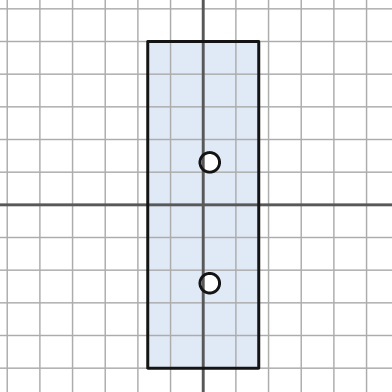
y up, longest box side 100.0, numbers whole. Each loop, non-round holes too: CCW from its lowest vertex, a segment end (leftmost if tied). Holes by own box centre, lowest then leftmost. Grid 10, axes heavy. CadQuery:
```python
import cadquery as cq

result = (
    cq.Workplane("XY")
    .moveTo(-17.0, -50.0)
    .lineTo(17.0, -50.0)
    .lineTo(17.0, 50.0)
    .lineTo(-17.0, 50.0)
    .close()
    .moveTo(2.0, -24.0)
    .circle(3.0)
    .moveTo(2.0, 13.0)
    .circle(3.0)
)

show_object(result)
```